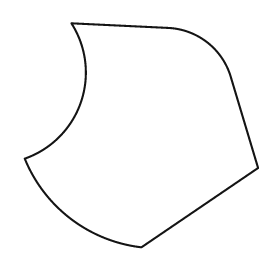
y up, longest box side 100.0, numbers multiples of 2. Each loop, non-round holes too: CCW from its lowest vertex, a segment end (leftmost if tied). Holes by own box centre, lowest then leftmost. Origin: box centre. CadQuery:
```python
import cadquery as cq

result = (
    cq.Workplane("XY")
    .moveTo(0.0, -48.0)
    .lineTo(50.0, -14.0)
    .lineTo(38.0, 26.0)
    .threePointArc((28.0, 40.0), (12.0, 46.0))
    .lineTo(-30.0, 48.0)
    .threePointArc((-26.0, 14.0), (-50.0, -10.0))
    .threePointArc((-30.0, -36.0), (0.0, -48.0))
    .close()
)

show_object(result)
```